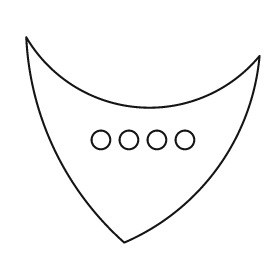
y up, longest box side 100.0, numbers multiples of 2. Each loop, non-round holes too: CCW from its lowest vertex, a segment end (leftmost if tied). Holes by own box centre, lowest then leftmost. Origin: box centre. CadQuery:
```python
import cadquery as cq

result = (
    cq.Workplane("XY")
    .moveTo(-8.0, -44.0)
    .threePointArc((32.0, -12.0), (50.0, 36.0))
    .threePointArc((-2.0, 14.0), (-50.0, 44.0))
    .threePointArc((-38.0, -4.0), (-8.0, -44.0))
    .close()
    .moveTo(-18.0, 0.0)
    .circle(4.0)
    .moveTo(-6.0, 0.0)
    .circle(4.0)
    .moveTo(6.0, 0.0)
    .circle(4.0)
    .moveTo(18.0, 0.0)
    .circle(4.0)
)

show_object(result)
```